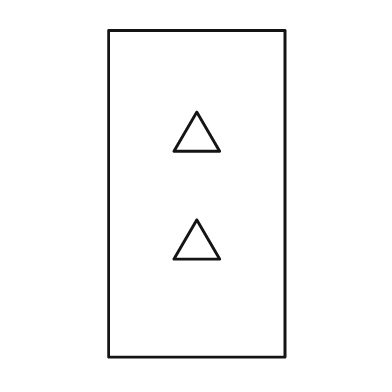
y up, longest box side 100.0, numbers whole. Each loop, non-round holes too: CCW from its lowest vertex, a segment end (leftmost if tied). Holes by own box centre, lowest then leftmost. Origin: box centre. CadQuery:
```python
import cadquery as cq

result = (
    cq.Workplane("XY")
    .moveTo(-27.0, -50.0)
    .lineTo(27.0, -50.0)
    .lineTo(27.0, 50.0)
    .lineTo(-27.0, 50.0)
    .close()
    .moveTo(-7.0, -20.0)
    .lineTo(7.0, -20.0)
    .lineTo(0.0, -8.0)
    .close()
    .moveTo(-7.0, 13.0)
    .lineTo(7.0, 13.0)
    .lineTo(0.0, 25.0)
    .close()
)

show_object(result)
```